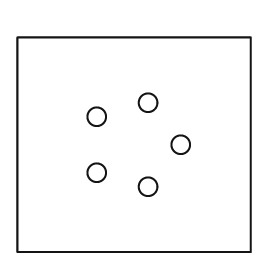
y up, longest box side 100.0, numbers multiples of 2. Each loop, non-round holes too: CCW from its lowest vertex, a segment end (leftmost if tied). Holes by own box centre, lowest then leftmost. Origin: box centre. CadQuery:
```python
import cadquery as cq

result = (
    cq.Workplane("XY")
    .moveTo(-50.0, -46.0)
    .lineTo(50.0, -46.0)
    .lineTo(50.0, 46.0)
    .lineTo(-50.0, 46.0)
    .close()
    .moveTo(6.0, -18.0)
    .circle(4.0)
    .moveTo(-16.0, -12.0)
    .circle(4.0)
    .moveTo(20.0, 0.0)
    .circle(4.0)
    .moveTo(-16.0, 12.0)
    .circle(4.0)
    .moveTo(6.0, 18.0)
    .circle(4.0)
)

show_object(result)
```